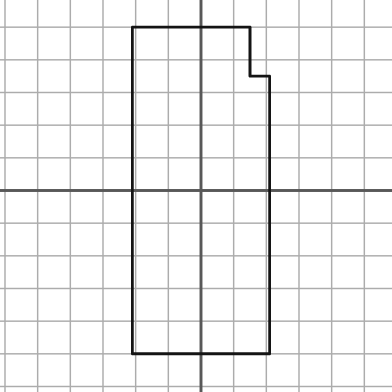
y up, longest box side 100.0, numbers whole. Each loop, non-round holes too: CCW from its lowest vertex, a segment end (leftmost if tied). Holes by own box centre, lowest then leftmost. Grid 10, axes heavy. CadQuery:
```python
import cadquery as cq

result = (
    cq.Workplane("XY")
    .moveTo(-21.0, -50.0)
    .lineTo(21.0, -50.0)
    .lineTo(21.0, 35.0)
    .lineTo(15.0, 35.0)
    .lineTo(15.0, 50.0)
    .lineTo(-21.0, 50.0)
    .close()
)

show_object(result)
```